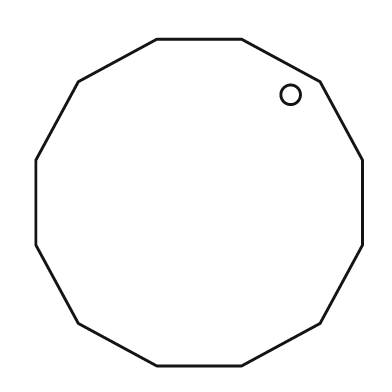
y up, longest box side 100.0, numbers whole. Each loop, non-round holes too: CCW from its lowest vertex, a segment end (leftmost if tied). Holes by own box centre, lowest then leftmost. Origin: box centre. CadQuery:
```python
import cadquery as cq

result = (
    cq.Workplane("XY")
    .moveTo(-13.0, -50.0)
    .lineTo(13.0, -50.0)
    .lineTo(37.0, -37.0)
    .lineTo(50.0, -13.0)
    .lineTo(50.0, 13.0)
    .lineTo(37.0, 37.0)
    .lineTo(13.0, 50.0)
    .lineTo(-13.0, 50.0)
    .lineTo(-37.0, 37.0)
    .lineTo(-50.0, 13.0)
    .lineTo(-50.0, -13.0)
    .lineTo(-37.0, -37.0)
    .close()
    .moveTo(28.0, 33.0)
    .circle(3.0)
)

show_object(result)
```